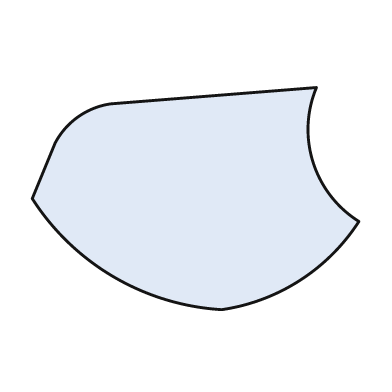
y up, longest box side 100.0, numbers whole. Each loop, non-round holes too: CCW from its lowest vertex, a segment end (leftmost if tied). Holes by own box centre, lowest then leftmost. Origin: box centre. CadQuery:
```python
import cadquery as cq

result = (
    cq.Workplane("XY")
    .moveTo(8.0, -34.0)
    .threePointArc((32.0, -25.0), (50.0, -7.0))
    .threePointArc((36.0, 11.0), (37.0, 34.0))
    .lineTo(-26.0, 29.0)
    .threePointArc((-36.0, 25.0), (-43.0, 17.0))
    .lineTo(-50.0, 0.0)
    .threePointArc((-25.0, -24.0), (8.0, -34.0))
    .close()
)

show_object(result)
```